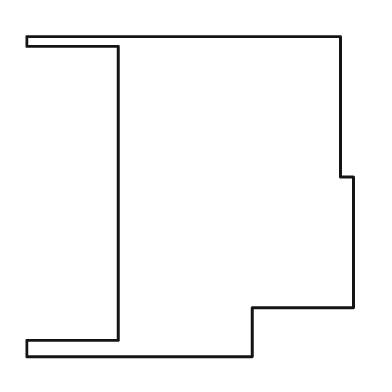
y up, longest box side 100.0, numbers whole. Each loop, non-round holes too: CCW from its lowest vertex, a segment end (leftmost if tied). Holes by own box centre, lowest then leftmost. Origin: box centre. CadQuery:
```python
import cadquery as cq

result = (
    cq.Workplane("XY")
    .moveTo(-50.0, -49.0)
    .lineTo(19.0, -49.0)
    .lineTo(19.0, -34.0)
    .lineTo(50.0, -34.0)
    .lineTo(50.0, 6.0)
    .lineTo(46.0, 6.0)
    .lineTo(46.0, 49.0)
    .lineTo(-50.0, 49.0)
    .lineTo(-50.0, 46.0)
    .lineTo(-22.0, 46.0)
    .lineTo(-22.0, -44.0)
    .lineTo(-50.0, -44.0)
    .close()
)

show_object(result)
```